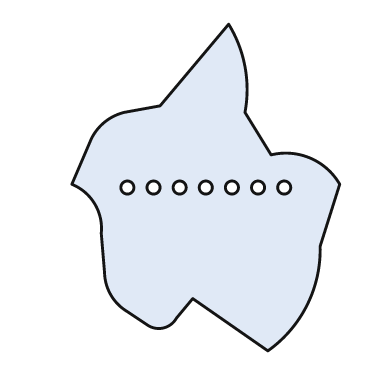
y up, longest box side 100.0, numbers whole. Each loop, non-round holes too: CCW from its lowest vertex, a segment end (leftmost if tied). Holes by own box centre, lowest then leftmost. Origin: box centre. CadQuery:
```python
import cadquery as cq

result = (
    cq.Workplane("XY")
    .moveTo(19.0, -50.0)
    .threePointArc((31.0, -36.0), (35.0, -18.0))
    .lineTo(41.0, 1.0)
    .threePointArc((32.0, 9.0), (20.0, 10.0))
    .lineTo(12.0, 23.0)
    .threePointArc((12.0, 37.0), (7.0, 50.0))
    .lineTo(-14.0, 25.0)
    .lineTo(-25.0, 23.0)
    .threePointArc((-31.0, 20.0), (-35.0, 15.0))
    .lineTo(-41.0, 1.0)
    .threePointArc((-34.0, -5.0), (-32.0, -14.0))
    .lineTo(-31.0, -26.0)
    .threePointArc((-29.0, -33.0), (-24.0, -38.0))
    .lineTo(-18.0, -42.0)
    .threePointArc((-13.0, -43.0), (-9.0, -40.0))
    .lineTo(-4.0, -34.0)
    .close()
    .moveTo(-24.0, 0.0)
    .circle(2.0)
    .moveTo(-16.0, 0.0)
    .circle(2.0)
    .moveTo(-8.0, 0.0)
    .circle(2.0)
    .moveTo(0.0, 0.0)
    .circle(2.0)
    .moveTo(8.0, 0.0)
    .circle(2.0)
    .moveTo(16.0, 0.0)
    .circle(2.0)
    .moveTo(24.0, 0.0)
    .circle(2.0)
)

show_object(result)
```